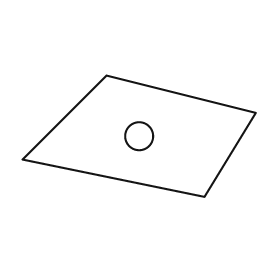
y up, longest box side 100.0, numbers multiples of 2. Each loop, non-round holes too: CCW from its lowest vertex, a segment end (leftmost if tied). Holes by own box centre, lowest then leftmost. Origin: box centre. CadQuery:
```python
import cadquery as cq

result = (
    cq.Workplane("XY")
    .moveTo(28.0, -26.0)
    .lineTo(50.0, 10.0)
    .lineTo(-14.0, 26.0)
    .lineTo(-50.0, -10.0)
    .close()
    .moveTo(0.0, 0.0)
    .circle(6.0)
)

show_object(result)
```